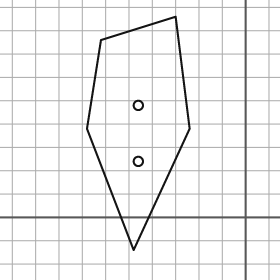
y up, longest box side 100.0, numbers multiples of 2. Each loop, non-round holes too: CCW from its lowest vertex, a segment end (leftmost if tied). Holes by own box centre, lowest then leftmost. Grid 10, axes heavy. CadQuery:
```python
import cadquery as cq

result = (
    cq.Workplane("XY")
    .moveTo(-48.0, -14.0)
    .lineTo(-24.0, 38.0)
    .lineTo(-30.0, 86.0)
    .lineTo(-62.0, 76.0)
    .lineTo(-68.0, 38.0)
    .close()
    .moveTo(-46.0, 24.0)
    .circle(2.0)
    .moveTo(-46.0, 48.0)
    .circle(2.0)
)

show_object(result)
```